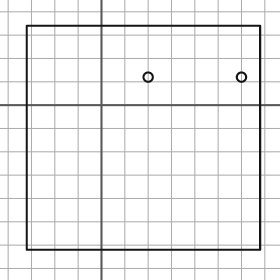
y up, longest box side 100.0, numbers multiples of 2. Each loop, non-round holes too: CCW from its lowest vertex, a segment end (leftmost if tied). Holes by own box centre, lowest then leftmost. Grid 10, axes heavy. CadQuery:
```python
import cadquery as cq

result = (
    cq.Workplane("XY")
    .moveTo(-32.0, -62.0)
    .lineTo(68.0, -62.0)
    .lineTo(68.0, 34.0)
    .lineTo(-32.0, 34.0)
    .close()
    .moveTo(20.0, 12.0)
    .circle(2.0)
    .moveTo(60.0, 12.0)
    .circle(2.0)
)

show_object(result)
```